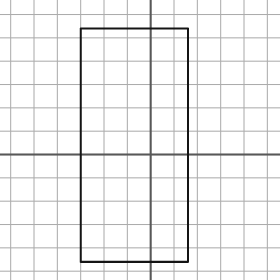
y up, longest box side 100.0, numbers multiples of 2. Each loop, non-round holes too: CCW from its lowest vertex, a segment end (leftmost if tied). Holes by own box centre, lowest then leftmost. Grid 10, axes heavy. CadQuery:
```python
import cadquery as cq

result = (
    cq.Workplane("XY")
    .moveTo(-30.0, -46.0)
    .lineTo(16.0, -46.0)
    .lineTo(16.0, 54.0)
    .lineTo(-30.0, 54.0)
    .close()
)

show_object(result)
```